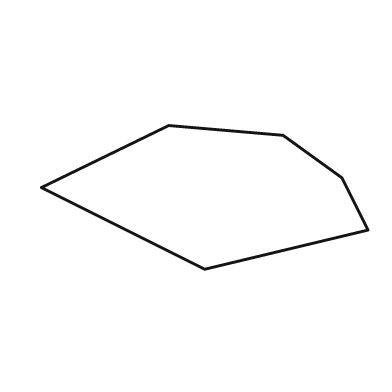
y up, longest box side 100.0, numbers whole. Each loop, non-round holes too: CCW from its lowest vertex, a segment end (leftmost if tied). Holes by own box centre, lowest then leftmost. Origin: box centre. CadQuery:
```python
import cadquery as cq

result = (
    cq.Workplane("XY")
    .moveTo(0.0, -22.0)
    .lineTo(50.0, -10.0)
    .lineTo(42.0, 6.0)
    .lineTo(24.0, 19.0)
    .lineTo(-11.0, 22.0)
    .lineTo(-50.0, 3.0)
    .close()
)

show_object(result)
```